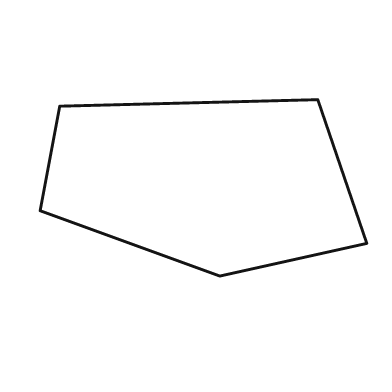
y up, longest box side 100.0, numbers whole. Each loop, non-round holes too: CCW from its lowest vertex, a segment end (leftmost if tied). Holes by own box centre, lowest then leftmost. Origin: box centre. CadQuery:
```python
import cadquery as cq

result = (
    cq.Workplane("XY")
    .moveTo(5.0, -27.0)
    .lineTo(50.0, -17.0)
    .lineTo(35.0, 27.0)
    .lineTo(-44.0, 25.0)
    .lineTo(-50.0, -7.0)
    .close()
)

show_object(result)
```